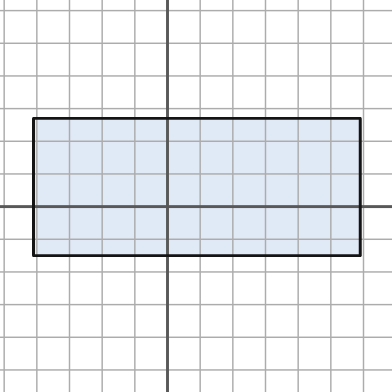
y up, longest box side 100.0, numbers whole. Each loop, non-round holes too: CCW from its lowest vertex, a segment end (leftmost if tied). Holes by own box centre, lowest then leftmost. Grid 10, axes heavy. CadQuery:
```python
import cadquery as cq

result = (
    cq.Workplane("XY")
    .moveTo(-41.0, -15.0)
    .lineTo(59.0, -15.0)
    .lineTo(59.0, 27.0)
    .lineTo(-41.0, 27.0)
    .close()
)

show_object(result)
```